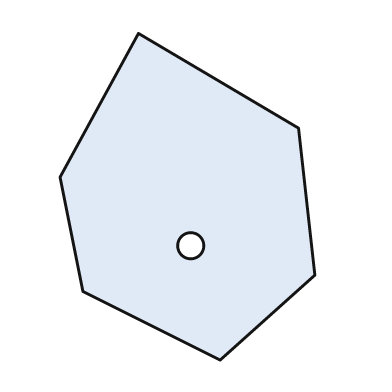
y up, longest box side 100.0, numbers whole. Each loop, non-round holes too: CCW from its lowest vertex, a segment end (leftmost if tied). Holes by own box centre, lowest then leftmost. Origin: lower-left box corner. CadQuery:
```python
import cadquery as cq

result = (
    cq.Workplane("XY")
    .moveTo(49.0, 0.0)
    .lineTo(78.0, 26.0)
    .lineTo(73.0, 71.0)
    .lineTo(24.0, 100.0)
    .lineTo(0.0, 56.0)
    .lineTo(7.0, 21.0)
    .close()
    .moveTo(40.0, 35.0)
    .circle(4.0)
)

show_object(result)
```